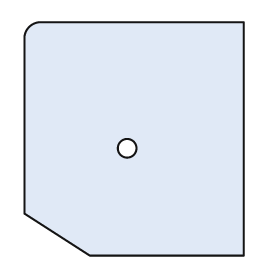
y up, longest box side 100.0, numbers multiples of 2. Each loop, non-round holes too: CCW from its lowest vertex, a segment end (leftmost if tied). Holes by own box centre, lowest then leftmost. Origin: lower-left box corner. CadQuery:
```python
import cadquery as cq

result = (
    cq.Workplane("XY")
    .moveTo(28.0, 0.0)
    .lineTo(94.0, 0.0)
    .lineTo(94.0, 100.0)
    .lineTo(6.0, 100.0)
    .threePointArc((2.0, 98.0), (0.0, 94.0))
    .lineTo(0.0, 18.0)
    .close()
    .moveTo(44.0, 46.0)
    .circle(4.0)
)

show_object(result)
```